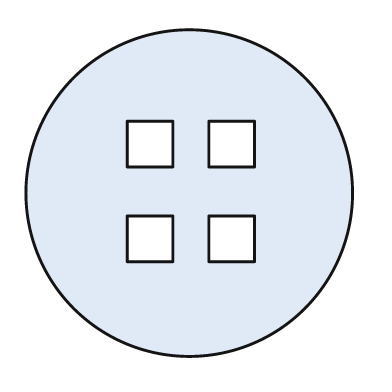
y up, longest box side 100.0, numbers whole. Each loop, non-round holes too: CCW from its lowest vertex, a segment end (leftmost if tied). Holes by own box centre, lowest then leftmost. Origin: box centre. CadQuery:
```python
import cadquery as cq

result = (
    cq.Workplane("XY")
    .moveTo(0.0, 0.0)
    .circle(50.0)
    .moveTo(-19.0, -21.0)
    .lineTo(-5.0, -21.0)
    .lineTo(-5.0, -7.0)
    .lineTo(-19.0, -7.0)
    .close()
    .moveTo(6.0, -21.0)
    .lineTo(20.0, -21.0)
    .lineTo(20.0, -7.0)
    .lineTo(6.0, -7.0)
    .close()
    .moveTo(-19.0, 8.0)
    .lineTo(-5.0, 8.0)
    .lineTo(-5.0, 22.0)
    .lineTo(-19.0, 22.0)
    .close()
    .moveTo(6.0, 8.0)
    .lineTo(20.0, 8.0)
    .lineTo(20.0, 22.0)
    .lineTo(6.0, 22.0)
    .close()
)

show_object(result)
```